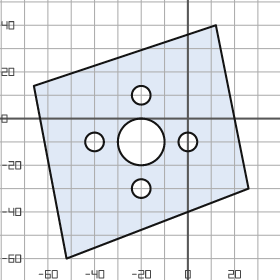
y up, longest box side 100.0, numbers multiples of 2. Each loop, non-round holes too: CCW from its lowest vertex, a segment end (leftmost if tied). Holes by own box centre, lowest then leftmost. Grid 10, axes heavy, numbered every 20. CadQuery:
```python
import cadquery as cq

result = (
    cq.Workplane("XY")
    .moveTo(-52.0, -60.0)
    .lineTo(26.0, -30.0)
    .lineTo(12.0, 40.0)
    .lineTo(-66.0, 14.0)
    .close()
    .moveTo(-20.0, -30.0)
    .circle(4.0)
    .moveTo(-40.0, -10.0)
    .circle(4.0)
    .moveTo(-20.0, -10.0)
    .circle(10.0)
    .moveTo(0.0, -10.0)
    .circle(4.0)
    .moveTo(-20.0, 10.0)
    .circle(4.0)
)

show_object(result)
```